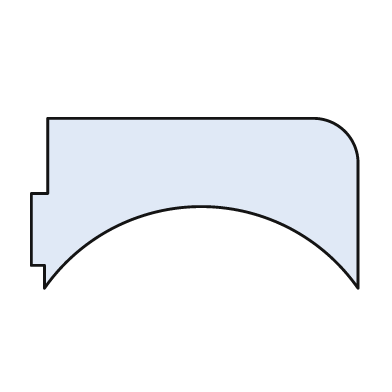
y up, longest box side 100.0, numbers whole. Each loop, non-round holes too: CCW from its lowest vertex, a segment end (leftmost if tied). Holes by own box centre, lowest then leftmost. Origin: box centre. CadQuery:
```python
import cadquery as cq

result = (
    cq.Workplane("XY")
    .moveTo(-46.0, -26.0)
    .threePointArc((2.0, -1.0), (50.0, -26.0))
    .lineTo(50.0, 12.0)
    .threePointArc((46.0, 22.0), (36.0, 26.0))
    .lineTo(-45.0, 26.0)
    .lineTo(-45.0, 3.0)
    .lineTo(-50.0, 3.0)
    .lineTo(-50.0, -19.0)
    .lineTo(-46.0, -19.0)
    .close()
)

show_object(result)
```